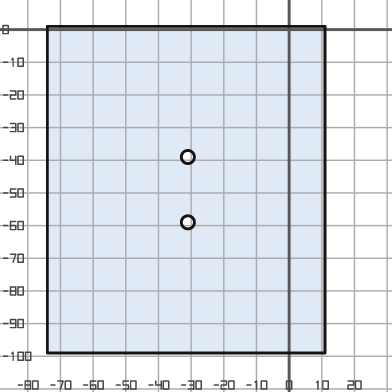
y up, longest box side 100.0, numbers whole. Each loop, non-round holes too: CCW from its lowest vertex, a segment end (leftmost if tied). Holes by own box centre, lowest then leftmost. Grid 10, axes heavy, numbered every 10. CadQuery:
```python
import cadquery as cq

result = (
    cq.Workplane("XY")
    .moveTo(-74.0, -99.0)
    .lineTo(11.0, -99.0)
    .lineTo(11.0, 1.0)
    .lineTo(-74.0, 1.0)
    .close()
    .moveTo(-31.0, -59.0)
    .circle(2.0)
    .moveTo(-31.0, -39.0)
    .circle(2.0)
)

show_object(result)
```